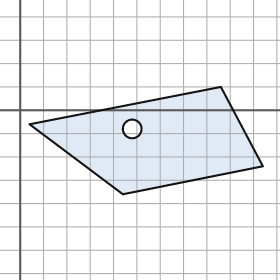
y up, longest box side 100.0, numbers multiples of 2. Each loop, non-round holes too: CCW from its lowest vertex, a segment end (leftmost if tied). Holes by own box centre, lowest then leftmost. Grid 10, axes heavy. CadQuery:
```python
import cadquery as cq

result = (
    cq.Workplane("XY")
    .moveTo(44.0, -36.0)
    .lineTo(104.0, -24.0)
    .lineTo(86.0, 10.0)
    .lineTo(4.0, -6.0)
    .close()
    .moveTo(48.0, -8.0)
    .circle(4.0)
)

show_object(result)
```